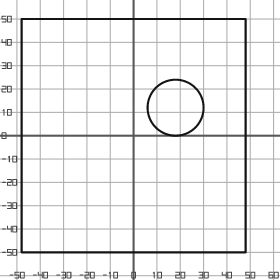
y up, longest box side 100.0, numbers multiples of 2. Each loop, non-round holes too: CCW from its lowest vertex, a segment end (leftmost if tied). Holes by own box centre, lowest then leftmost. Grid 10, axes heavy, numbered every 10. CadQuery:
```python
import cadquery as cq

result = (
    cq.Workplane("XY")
    .moveTo(-48.0, -50.0)
    .lineTo(48.0, -50.0)
    .lineTo(48.0, 50.0)
    .lineTo(-48.0, 50.0)
    .close()
    .moveTo(18.0, 12.0)
    .circle(12.0)
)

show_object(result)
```